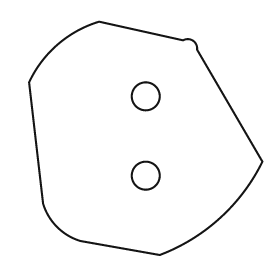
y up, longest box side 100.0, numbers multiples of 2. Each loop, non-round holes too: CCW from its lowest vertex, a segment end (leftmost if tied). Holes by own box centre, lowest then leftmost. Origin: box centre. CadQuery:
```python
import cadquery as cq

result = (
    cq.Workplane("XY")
    .moveTo(6.0, -50.0)
    .threePointArc((32.0, -34.0), (50.0, -10.0))
    .lineTo(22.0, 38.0)
    .threePointArc((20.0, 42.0), (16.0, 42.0))
    .lineTo(-20.0, 50.0)
    .threePointArc((-38.0, 40.0), (-50.0, 24.0))
    .lineTo(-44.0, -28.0)
    .threePointArc((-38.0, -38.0), (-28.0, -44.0))
    .close()
    .moveTo(0.0, -16.0)
    .circle(6.0)
    .moveTo(0.0, 18.0)
    .circle(6.0)
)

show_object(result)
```